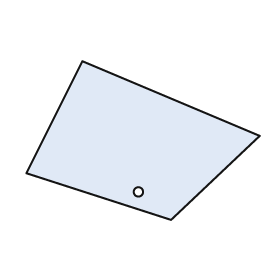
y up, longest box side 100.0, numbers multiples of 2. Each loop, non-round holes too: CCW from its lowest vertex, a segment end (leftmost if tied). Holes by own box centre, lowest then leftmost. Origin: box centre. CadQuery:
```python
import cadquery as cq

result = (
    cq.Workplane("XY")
    .moveTo(12.0, -34.0)
    .lineTo(50.0, 2.0)
    .lineTo(-26.0, 34.0)
    .lineTo(-50.0, -14.0)
    .close()
    .moveTo(-2.0, -22.0)
    .circle(2.0)
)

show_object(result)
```